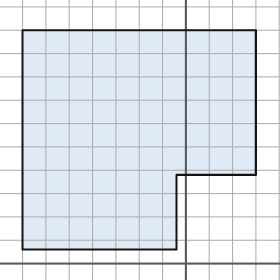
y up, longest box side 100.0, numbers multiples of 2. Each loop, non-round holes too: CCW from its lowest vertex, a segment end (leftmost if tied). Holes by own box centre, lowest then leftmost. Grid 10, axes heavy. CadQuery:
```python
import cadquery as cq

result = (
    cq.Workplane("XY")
    .moveTo(-70.0, 6.0)
    .lineTo(-4.0, 6.0)
    .lineTo(-4.0, 38.0)
    .lineTo(30.0, 38.0)
    .lineTo(30.0, 100.0)
    .lineTo(-70.0, 100.0)
    .close()
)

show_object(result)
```